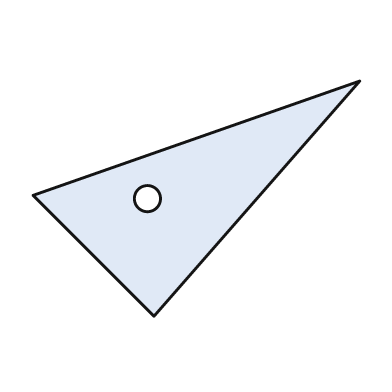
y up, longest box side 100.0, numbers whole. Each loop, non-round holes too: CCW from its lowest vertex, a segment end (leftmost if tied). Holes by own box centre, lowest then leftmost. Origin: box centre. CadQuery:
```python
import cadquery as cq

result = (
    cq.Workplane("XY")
    .moveTo(-13.0, -36.0)
    .lineTo(50.0, 36.0)
    .lineTo(-50.0, 1.0)
    .close()
    .moveTo(-15.0, 0.0)
    .circle(4.0)
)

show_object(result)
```